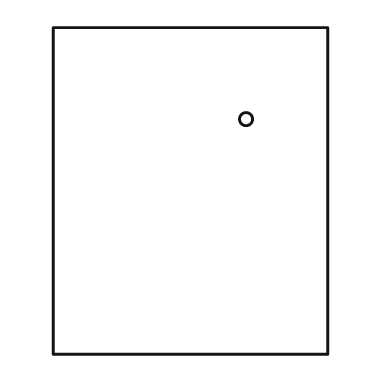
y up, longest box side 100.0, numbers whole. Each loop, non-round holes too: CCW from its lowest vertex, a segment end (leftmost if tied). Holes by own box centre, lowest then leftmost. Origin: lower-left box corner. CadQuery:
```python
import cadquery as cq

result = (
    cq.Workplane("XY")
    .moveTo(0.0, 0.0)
    .lineTo(84.0, 0.0)
    .lineTo(84.0, 100.0)
    .lineTo(0.0, 100.0)
    .close()
    .moveTo(59.0, 72.0)
    .circle(2.0)
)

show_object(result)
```